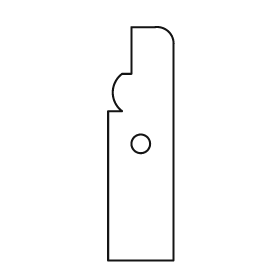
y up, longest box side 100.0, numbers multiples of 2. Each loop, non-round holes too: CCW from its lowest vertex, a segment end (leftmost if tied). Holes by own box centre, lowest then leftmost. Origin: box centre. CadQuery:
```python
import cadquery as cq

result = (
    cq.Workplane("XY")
    .moveTo(-14.0, -50.0)
    .lineTo(14.0, -50.0)
    .lineTo(14.0, 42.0)
    .threePointArc((12.0, 48.0), (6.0, 50.0))
    .lineTo(-4.0, 50.0)
    .lineTo(-4.0, 30.0)
    .lineTo(-8.0, 30.0)
    .threePointArc((-12.0, 22.0), (-8.0, 14.0))
    .lineTo(-14.0, 14.0)
    .close()
    .moveTo(0.0, 0.0)
    .circle(4.0)
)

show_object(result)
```